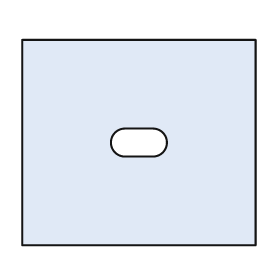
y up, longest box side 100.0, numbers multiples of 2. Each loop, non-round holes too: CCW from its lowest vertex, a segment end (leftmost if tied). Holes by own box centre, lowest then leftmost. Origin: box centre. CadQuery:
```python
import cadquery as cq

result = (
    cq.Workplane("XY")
    .moveTo(-50.0, -44.0)
    .lineTo(50.0, -44.0)
    .lineTo(50.0, 44.0)
    .lineTo(-50.0, 44.0)
    .close()
    .moveTo(-6.0, -6.0)
    .lineTo(6.0, -6.0)
    .threePointArc((12.0, 0.0), (6.0, 6.0))
    .lineTo(-6.0, 6.0)
    .threePointArc((-12.0, 0.0), (-6.0, -6.0))
    .close()
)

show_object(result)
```